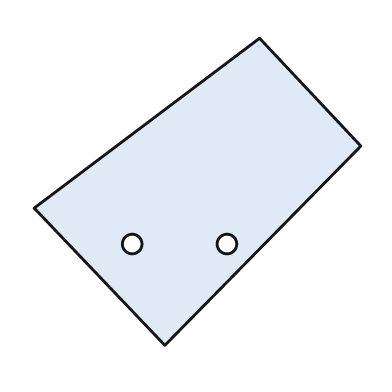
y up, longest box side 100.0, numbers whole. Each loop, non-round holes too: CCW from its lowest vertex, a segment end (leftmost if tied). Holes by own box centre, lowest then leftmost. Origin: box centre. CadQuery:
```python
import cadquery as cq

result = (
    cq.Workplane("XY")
    .moveTo(-10.0, -47.0)
    .lineTo(50.0, 14.0)
    .lineTo(19.0, 47.0)
    .lineTo(-50.0, -5.0)
    .close()
    .moveTo(-20.0, -16.0)
    .circle(3.0)
    .moveTo(9.0, -16.0)
    .circle(3.0)
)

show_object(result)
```